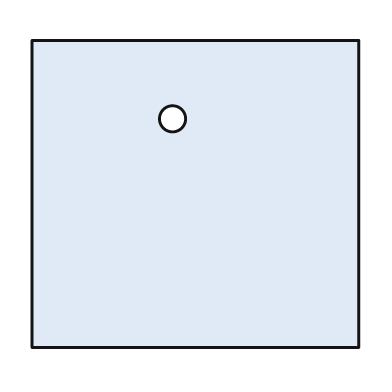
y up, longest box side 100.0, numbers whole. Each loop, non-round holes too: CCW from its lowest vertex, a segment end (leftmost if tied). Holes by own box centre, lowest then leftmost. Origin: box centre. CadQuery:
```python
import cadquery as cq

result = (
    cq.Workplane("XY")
    .moveTo(-50.0, -47.0)
    .lineTo(50.0, -47.0)
    .lineTo(50.0, 47.0)
    .lineTo(-50.0, 47.0)
    .close()
    .moveTo(-7.0, 23.0)
    .circle(4.0)
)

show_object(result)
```